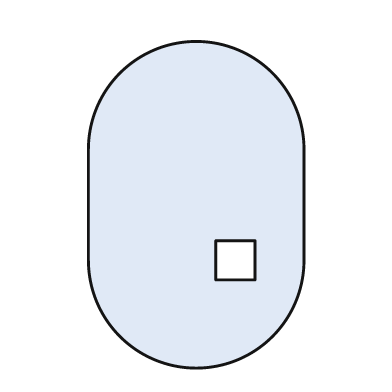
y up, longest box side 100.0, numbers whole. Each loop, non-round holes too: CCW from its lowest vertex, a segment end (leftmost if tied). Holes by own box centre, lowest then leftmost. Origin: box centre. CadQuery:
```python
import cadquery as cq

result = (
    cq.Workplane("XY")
    .moveTo(-33.0, -17.0)
    .threePointArc((0.0, -50.0), (33.0, -17.0))
    .lineTo(33.0, 17.0)
    .threePointArc((0.0, 50.0), (-33.0, 17.0))
    .close()
    .moveTo(6.0, -23.0)
    .lineTo(18.0, -23.0)
    .lineTo(18.0, -11.0)
    .lineTo(6.0, -11.0)
    .close()
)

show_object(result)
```